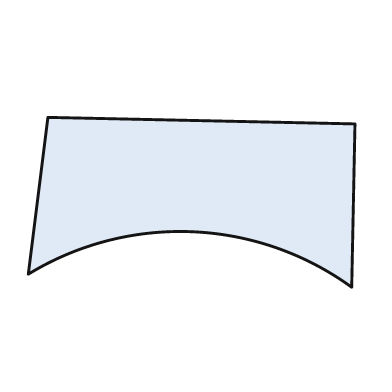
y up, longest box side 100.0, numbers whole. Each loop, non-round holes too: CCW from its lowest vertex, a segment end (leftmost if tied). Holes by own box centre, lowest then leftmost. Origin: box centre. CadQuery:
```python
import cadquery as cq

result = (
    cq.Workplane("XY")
    .moveTo(49.0, -26.0)
    .lineTo(50.0, 24.0)
    .lineTo(-44.0, 26.0)
    .lineTo(-50.0, -22.0)
    .threePointArc((0.0, -9.0), (49.0, -26.0))
    .close()
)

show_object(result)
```